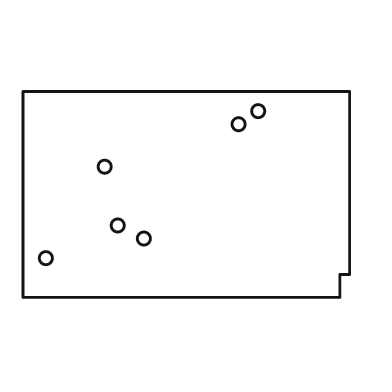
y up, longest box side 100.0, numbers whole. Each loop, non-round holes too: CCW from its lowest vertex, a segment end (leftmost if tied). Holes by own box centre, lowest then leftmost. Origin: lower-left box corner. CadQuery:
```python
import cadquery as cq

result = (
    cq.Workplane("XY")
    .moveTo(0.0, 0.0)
    .lineTo(97.0, 0.0)
    .lineTo(97.0, 7.0)
    .lineTo(100.0, 7.0)
    .lineTo(100.0, 63.0)
    .lineTo(0.0, 63.0)
    .close()
    .moveTo(7.0, 12.0)
    .circle(2.0)
    .moveTo(37.0, 18.0)
    .circle(2.0)
    .moveTo(29.0, 22.0)
    .circle(2.0)
    .moveTo(25.0, 40.0)
    .circle(2.0)
    .moveTo(66.0, 53.0)
    .circle(2.0)
    .moveTo(72.0, 57.0)
    .circle(2.0)
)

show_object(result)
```